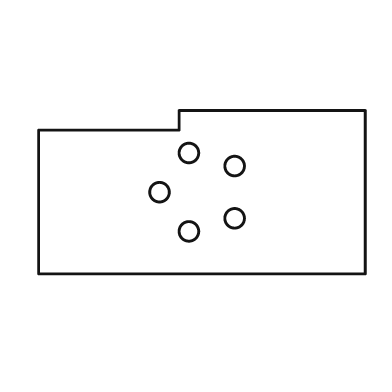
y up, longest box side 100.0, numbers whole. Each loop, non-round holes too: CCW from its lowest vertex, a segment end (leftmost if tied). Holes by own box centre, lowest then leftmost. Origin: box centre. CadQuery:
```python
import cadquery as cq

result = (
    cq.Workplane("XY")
    .moveTo(-50.0, -25.0)
    .lineTo(50.0, -25.0)
    .lineTo(50.0, 25.0)
    .lineTo(-7.0, 25.0)
    .lineTo(-7.0, 19.0)
    .lineTo(-50.0, 19.0)
    .close()
    .moveTo(-4.0, -12.0)
    .circle(3.0)
    .moveTo(10.0, -8.0)
    .circle(3.0)
    .moveTo(-13.0, 0.0)
    .circle(3.0)
    .moveTo(10.0, 8.0)
    .circle(3.0)
    .moveTo(-4.0, 12.0)
    .circle(3.0)
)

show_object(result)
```